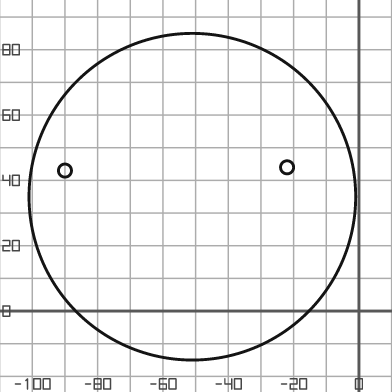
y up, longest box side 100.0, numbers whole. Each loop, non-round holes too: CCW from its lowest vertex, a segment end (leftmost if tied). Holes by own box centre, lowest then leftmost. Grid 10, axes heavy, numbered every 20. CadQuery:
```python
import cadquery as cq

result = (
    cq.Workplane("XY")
    .moveTo(-51.0, 35.0)
    .circle(50.0)
    .moveTo(-90.0, 43.0)
    .circle(2.0)
    .moveTo(-22.0, 44.0)
    .circle(2.0)
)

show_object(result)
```